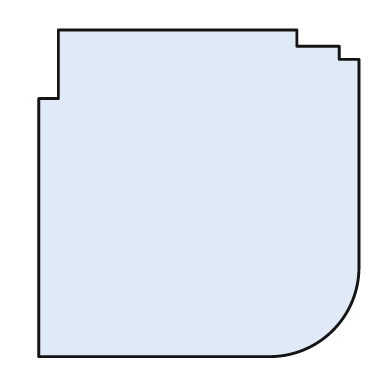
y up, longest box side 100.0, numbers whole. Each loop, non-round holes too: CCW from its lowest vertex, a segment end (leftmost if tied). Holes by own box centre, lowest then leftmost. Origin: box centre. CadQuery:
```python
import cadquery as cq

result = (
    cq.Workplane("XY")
    .moveTo(-49.0, -50.0)
    .lineTo(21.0, -50.0)
    .threePointArc((41.0, -42.0), (49.0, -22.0))
    .lineTo(49.0, 41.0)
    .lineTo(43.0, 41.0)
    .lineTo(43.0, 45.0)
    .lineTo(30.0, 45.0)
    .lineTo(30.0, 50.0)
    .lineTo(-43.0, 50.0)
    .lineTo(-43.0, 29.0)
    .lineTo(-49.0, 29.0)
    .close()
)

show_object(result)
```